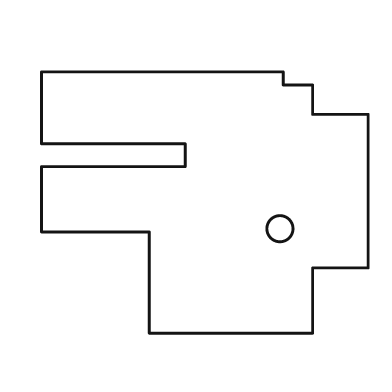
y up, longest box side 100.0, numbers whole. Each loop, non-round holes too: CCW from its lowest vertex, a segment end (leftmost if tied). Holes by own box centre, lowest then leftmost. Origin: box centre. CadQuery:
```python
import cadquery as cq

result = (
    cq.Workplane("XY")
    .moveTo(-17.0, -40.0)
    .lineTo(33.0, -40.0)
    .lineTo(33.0, -20.0)
    .lineTo(50.0, -20.0)
    .lineTo(50.0, 27.0)
    .lineTo(33.0, 27.0)
    .lineTo(33.0, 36.0)
    .lineTo(24.0, 36.0)
    .lineTo(24.0, 40.0)
    .lineTo(-50.0, 40.0)
    .lineTo(-50.0, 18.0)
    .lineTo(-6.0, 18.0)
    .lineTo(-6.0, 11.0)
    .lineTo(-50.0, 11.0)
    .lineTo(-50.0, -9.0)
    .lineTo(-17.0, -9.0)
    .close()
    .moveTo(23.0, -8.0)
    .circle(4.0)
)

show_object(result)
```